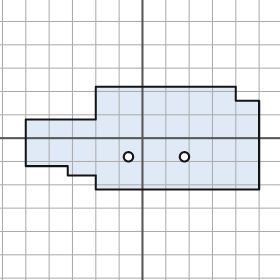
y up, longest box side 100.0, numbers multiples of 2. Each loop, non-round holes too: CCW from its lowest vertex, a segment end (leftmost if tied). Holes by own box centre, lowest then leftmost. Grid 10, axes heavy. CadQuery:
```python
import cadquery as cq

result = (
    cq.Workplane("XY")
    .moveTo(-20.0, -22.0)
    .lineTo(50.0, -22.0)
    .lineTo(50.0, 16.0)
    .lineTo(40.0, 16.0)
    .lineTo(40.0, 22.0)
    .lineTo(-20.0, 22.0)
    .lineTo(-20.0, 8.0)
    .lineTo(-50.0, 8.0)
    .lineTo(-50.0, -12.0)
    .lineTo(-32.0, -12.0)
    .lineTo(-32.0, -16.0)
    .lineTo(-20.0, -16.0)
    .close()
    .moveTo(-6.0, -8.0)
    .circle(2.0)
    .moveTo(18.0, -8.0)
    .circle(2.0)
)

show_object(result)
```